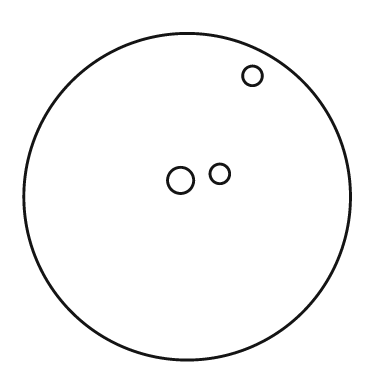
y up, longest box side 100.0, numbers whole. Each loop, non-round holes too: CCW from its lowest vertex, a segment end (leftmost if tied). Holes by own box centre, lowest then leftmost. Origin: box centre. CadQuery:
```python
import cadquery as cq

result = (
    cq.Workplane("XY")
    .moveTo(0.0, 0.0)
    .circle(50.0)
    .moveTo(-2.0, 5.0)
    .circle(4.0)
    .moveTo(10.0, 7.0)
    .circle(3.0)
    .moveTo(20.0, 37.0)
    .circle(3.0)
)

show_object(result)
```